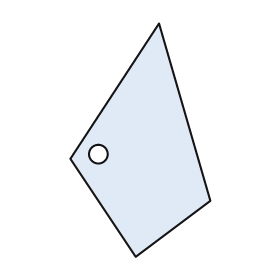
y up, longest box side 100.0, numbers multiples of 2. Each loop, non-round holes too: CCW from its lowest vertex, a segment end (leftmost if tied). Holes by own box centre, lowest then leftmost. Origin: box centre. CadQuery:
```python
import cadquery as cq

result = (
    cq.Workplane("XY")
    .moveTo(-2.0, -50.0)
    .lineTo(30.0, -26.0)
    .lineTo(8.0, 50.0)
    .lineTo(-30.0, -8.0)
    .close()
    .moveTo(-18.0, -6.0)
    .circle(4.0)
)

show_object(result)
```